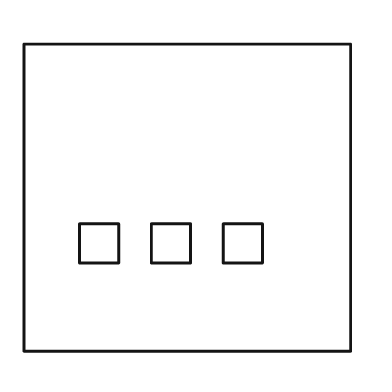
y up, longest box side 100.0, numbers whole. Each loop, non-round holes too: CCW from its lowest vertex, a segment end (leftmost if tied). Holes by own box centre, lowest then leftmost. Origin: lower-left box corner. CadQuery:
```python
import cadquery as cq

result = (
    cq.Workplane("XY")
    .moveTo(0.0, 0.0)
    .lineTo(100.0, 0.0)
    .lineTo(100.0, 94.0)
    .lineTo(0.0, 94.0)
    .close()
    .moveTo(17.0, 27.0)
    .lineTo(29.0, 27.0)
    .lineTo(29.0, 39.0)
    .lineTo(17.0, 39.0)
    .close()
    .moveTo(39.0, 27.0)
    .lineTo(51.0, 27.0)
    .lineTo(51.0, 39.0)
    .lineTo(39.0, 39.0)
    .close()
    .moveTo(61.0, 27.0)
    .lineTo(73.0, 27.0)
    .lineTo(73.0, 39.0)
    .lineTo(61.0, 39.0)
    .close()
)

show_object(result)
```